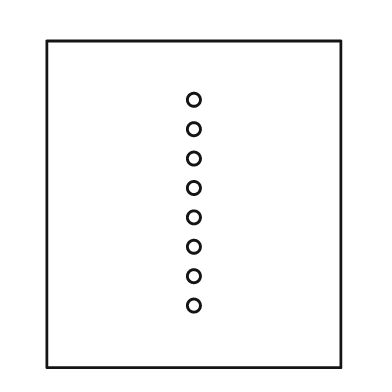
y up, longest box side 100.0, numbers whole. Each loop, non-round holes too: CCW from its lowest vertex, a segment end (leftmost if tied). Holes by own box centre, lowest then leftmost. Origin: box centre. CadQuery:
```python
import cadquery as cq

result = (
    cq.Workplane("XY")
    .moveTo(-45.0, -50.0)
    .lineTo(45.0, -50.0)
    .lineTo(45.0, 50.0)
    .lineTo(-45.0, 50.0)
    .close()
    .moveTo(0.0, -31.0)
    .circle(2.0)
    .moveTo(0.0, -22.0)
    .circle(2.0)
    .moveTo(0.0, -13.0)
    .circle(2.0)
    .moveTo(0.0, -4.0)
    .circle(2.0)
    .moveTo(0.0, 5.0)
    .circle(2.0)
    .moveTo(0.0, 14.0)
    .circle(2.0)
    .moveTo(0.0, 23.0)
    .circle(2.0)
    .moveTo(0.0, 32.0)
    .circle(2.0)
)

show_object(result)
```